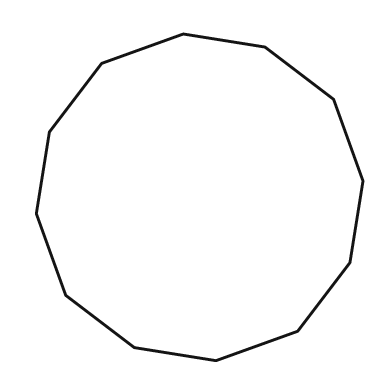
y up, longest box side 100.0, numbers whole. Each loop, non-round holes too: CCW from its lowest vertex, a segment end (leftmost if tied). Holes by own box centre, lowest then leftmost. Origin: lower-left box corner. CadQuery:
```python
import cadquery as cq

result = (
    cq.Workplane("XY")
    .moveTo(55.0, 0.0)
    .lineTo(80.0, 9.0)
    .lineTo(96.0, 30.0)
    .lineTo(100.0, 55.0)
    .lineTo(91.0, 80.0)
    .lineTo(70.0, 96.0)
    .lineTo(45.0, 100.0)
    .lineTo(20.0, 91.0)
    .lineTo(4.0, 70.0)
    .lineTo(0.0, 45.0)
    .lineTo(9.0, 20.0)
    .lineTo(30.0, 4.0)
    .close()
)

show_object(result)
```